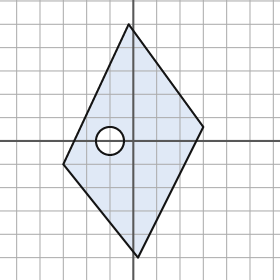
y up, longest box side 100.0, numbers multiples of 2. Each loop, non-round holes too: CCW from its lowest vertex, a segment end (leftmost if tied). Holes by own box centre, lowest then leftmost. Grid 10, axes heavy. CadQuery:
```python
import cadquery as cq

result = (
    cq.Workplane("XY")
    .moveTo(2.0, -50.0)
    .lineTo(30.0, 6.0)
    .lineTo(-2.0, 50.0)
    .lineTo(-30.0, -10.0)
    .close()
    .moveTo(-10.0, 0.0)
    .circle(6.0)
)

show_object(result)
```